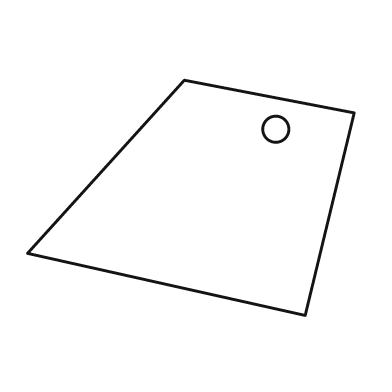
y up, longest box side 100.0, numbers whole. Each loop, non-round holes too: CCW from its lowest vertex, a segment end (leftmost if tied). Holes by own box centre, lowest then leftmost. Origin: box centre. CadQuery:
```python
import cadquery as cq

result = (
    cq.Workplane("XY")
    .moveTo(35.0, -36.0)
    .lineTo(50.0, 26.0)
    .lineTo(-2.0, 36.0)
    .lineTo(-50.0, -17.0)
    .close()
    .moveTo(26.0, 21.0)
    .circle(4.0)
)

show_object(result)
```